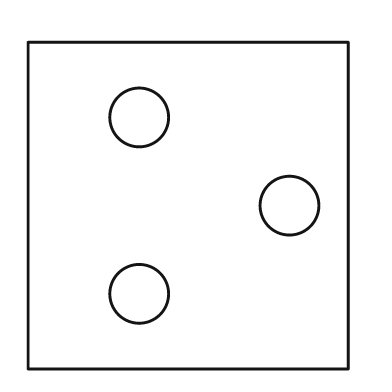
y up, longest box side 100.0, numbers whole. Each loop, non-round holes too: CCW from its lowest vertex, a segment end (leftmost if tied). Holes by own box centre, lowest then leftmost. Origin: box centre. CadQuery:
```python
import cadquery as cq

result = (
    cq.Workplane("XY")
    .moveTo(-49.0, -50.0)
    .lineTo(49.0, -50.0)
    .lineTo(49.0, 50.0)
    .lineTo(-49.0, 50.0)
    .close()
    .moveTo(-15.0, -27.0)
    .circle(9.0)
    .moveTo(31.0, 0.0)
    .circle(9.0)
    .moveTo(-15.0, 27.0)
    .circle(9.0)
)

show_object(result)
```